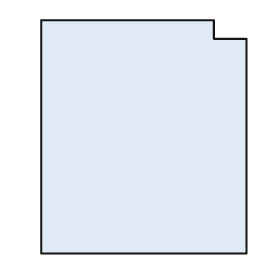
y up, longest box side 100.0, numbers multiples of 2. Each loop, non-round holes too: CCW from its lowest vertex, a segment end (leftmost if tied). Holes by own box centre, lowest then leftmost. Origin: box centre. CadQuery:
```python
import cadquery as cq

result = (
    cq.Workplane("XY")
    .moveTo(-44.0, -50.0)
    .lineTo(44.0, -50.0)
    .lineTo(44.0, 42.0)
    .lineTo(30.0, 42.0)
    .lineTo(30.0, 50.0)
    .lineTo(-44.0, 50.0)
    .close()
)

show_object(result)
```